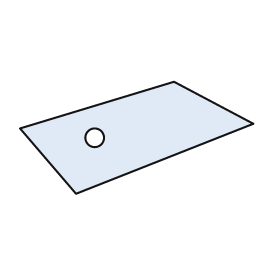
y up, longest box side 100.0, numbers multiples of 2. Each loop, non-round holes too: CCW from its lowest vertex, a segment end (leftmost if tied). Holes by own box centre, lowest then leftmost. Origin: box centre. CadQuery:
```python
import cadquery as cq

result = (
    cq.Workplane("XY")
    .moveTo(-26.0, -24.0)
    .lineTo(50.0, 6.0)
    .lineTo(16.0, 24.0)
    .lineTo(-50.0, 4.0)
    .close()
    .moveTo(-18.0, 0.0)
    .circle(4.0)
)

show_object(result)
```